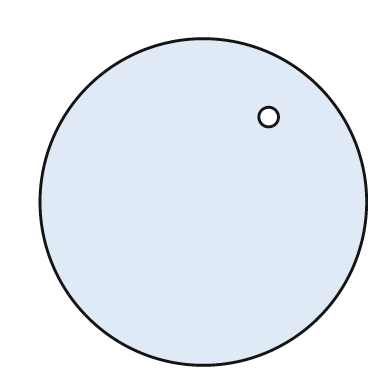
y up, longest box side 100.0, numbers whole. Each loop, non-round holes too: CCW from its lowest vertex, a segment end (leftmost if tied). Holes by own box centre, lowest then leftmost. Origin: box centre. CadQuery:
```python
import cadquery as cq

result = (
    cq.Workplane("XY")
    .moveTo(0.0, 0.0)
    .circle(50.0)
    .moveTo(20.0, 26.0)
    .circle(3.0)
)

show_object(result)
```